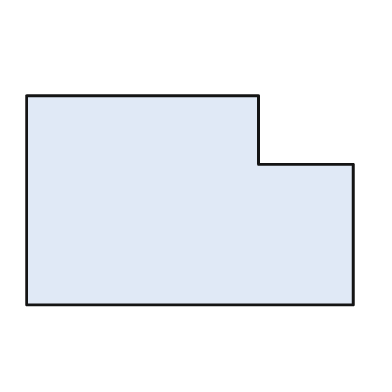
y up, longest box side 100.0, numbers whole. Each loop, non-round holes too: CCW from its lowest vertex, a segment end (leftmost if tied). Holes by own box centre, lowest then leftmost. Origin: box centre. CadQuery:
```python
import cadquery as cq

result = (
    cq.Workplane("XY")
    .moveTo(-50.0, -32.0)
    .lineTo(50.0, -32.0)
    .lineTo(50.0, 11.0)
    .lineTo(21.0, 11.0)
    .lineTo(21.0, 32.0)
    .lineTo(-50.0, 32.0)
    .close()
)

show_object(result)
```